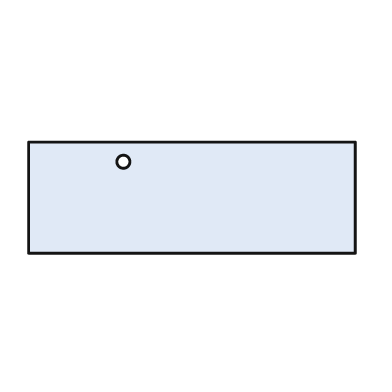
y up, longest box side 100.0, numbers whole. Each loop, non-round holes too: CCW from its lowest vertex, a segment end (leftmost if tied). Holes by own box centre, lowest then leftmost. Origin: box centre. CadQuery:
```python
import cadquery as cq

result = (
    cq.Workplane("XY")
    .moveTo(-50.0, -17.0)
    .lineTo(50.0, -17.0)
    .lineTo(50.0, 17.0)
    .lineTo(-50.0, 17.0)
    .close()
    .moveTo(-21.0, 11.0)
    .circle(2.0)
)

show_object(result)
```